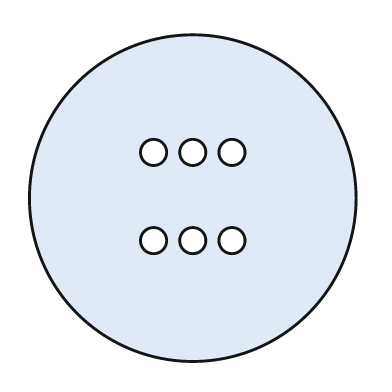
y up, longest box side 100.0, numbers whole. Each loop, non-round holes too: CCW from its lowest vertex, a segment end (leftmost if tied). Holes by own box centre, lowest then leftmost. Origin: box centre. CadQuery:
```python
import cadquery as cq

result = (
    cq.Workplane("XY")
    .moveTo(0.0, 0.0)
    .circle(50.0)
    .moveTo(-12.0, -13.0)
    .circle(4.0)
    .moveTo(0.0, -13.0)
    .circle(4.0)
    .moveTo(12.0, -13.0)
    .circle(4.0)
    .moveTo(-12.0, 14.0)
    .circle(4.0)
    .moveTo(0.0, 14.0)
    .circle(4.0)
    .moveTo(12.0, 14.0)
    .circle(4.0)
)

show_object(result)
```